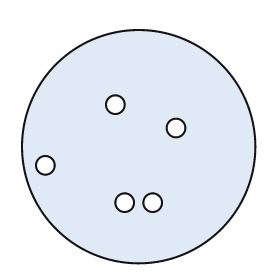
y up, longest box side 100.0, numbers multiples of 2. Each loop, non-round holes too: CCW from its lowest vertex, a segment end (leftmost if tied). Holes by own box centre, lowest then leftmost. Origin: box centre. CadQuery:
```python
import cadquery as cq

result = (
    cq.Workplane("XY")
    .moveTo(0.0, 0.0)
    .circle(50.0)
    .moveTo(-6.0, -24.0)
    .circle(4.0)
    .moveTo(6.0, -24.0)
    .circle(4.0)
    .moveTo(-40.0, -8.0)
    .circle(4.0)
    .moveTo(16.0, 8.0)
    .circle(4.0)
    .moveTo(-10.0, 18.0)
    .circle(4.0)
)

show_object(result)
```